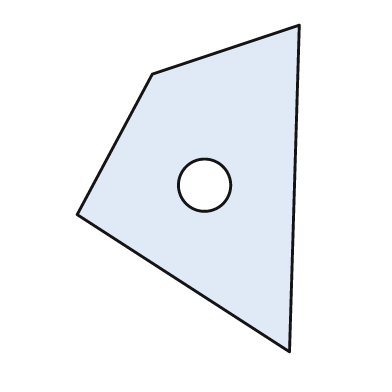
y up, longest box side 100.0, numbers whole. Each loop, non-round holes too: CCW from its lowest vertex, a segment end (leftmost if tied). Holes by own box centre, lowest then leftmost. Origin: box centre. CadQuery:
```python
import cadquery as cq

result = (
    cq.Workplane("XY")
    .moveTo(31.0, -50.0)
    .lineTo(34.0, 50.0)
    .lineTo(-11.0, 35.0)
    .lineTo(-34.0, -8.0)
    .close()
    .moveTo(5.0, 1.0)
    .circle(8.0)
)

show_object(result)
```